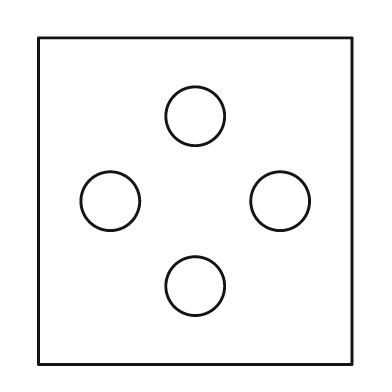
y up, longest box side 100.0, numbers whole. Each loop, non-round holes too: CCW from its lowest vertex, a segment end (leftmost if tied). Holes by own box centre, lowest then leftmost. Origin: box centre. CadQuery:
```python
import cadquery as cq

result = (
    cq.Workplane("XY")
    .moveTo(-48.0, -50.0)
    .lineTo(48.0, -50.0)
    .lineTo(48.0, 50.0)
    .lineTo(-48.0, 50.0)
    .close()
    .moveTo(0.0, -26.0)
    .circle(9.0)
    .moveTo(-26.0, 0.0)
    .circle(9.0)
    .moveTo(26.0, 0.0)
    .circle(9.0)
    .moveTo(0.0, 26.0)
    .circle(9.0)
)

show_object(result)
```